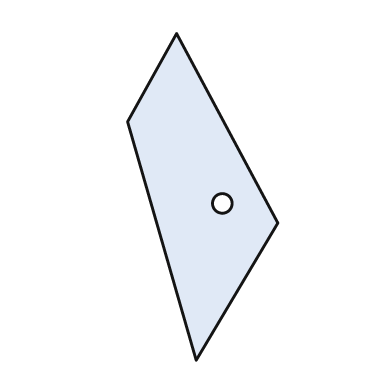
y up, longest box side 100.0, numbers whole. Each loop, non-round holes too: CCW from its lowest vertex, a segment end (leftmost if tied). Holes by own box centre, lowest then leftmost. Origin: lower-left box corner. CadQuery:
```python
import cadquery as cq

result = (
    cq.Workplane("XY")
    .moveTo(21.0, 0.0)
    .lineTo(46.0, 42.0)
    .lineTo(15.0, 100.0)
    .lineTo(0.0, 73.0)
    .close()
    .moveTo(29.0, 48.0)
    .circle(3.0)
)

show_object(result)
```